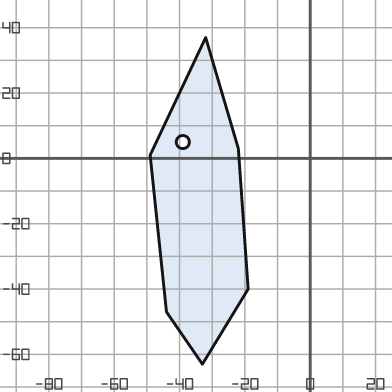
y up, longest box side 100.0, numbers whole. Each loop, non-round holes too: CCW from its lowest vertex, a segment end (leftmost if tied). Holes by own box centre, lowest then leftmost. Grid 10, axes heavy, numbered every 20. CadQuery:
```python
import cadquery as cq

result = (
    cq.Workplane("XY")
    .moveTo(-33.0, -63.0)
    .lineTo(-19.0, -40.0)
    .lineTo(-22.0, 3.0)
    .lineTo(-32.0, 37.0)
    .lineTo(-49.0, 1.0)
    .lineTo(-44.0, -47.0)
    .close()
    .moveTo(-39.0, 5.0)
    .circle(2.0)
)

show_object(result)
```